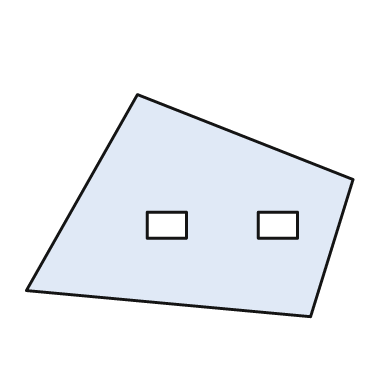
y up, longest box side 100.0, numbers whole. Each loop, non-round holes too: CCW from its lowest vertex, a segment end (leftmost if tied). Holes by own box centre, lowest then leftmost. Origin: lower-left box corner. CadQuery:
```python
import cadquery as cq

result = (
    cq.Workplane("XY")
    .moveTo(87.0, 0.0)
    .lineTo(100.0, 42.0)
    .lineTo(34.0, 68.0)
    .lineTo(0.0, 8.0)
    .close()
    .moveTo(37.0, 24.0)
    .lineTo(49.0, 24.0)
    .lineTo(49.0, 32.0)
    .lineTo(37.0, 32.0)
    .close()
    .moveTo(71.0, 24.0)
    .lineTo(83.0, 24.0)
    .lineTo(83.0, 32.0)
    .lineTo(71.0, 32.0)
    .close()
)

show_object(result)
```